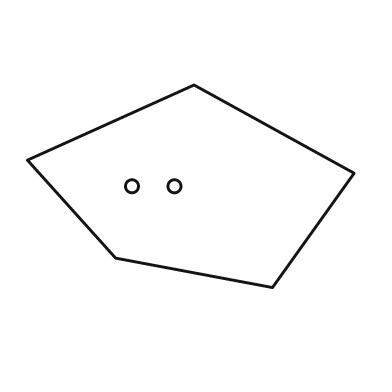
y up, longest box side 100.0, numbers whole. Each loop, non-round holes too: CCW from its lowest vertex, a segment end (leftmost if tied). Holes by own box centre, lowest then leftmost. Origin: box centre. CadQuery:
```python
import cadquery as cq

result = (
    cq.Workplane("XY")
    .moveTo(25.0, -31.0)
    .lineTo(50.0, 4.0)
    .lineTo(1.0, 31.0)
    .lineTo(-50.0, 8.0)
    .lineTo(-23.0, -22.0)
    .close()
    .moveTo(-18.0, 0.0)
    .circle(2.0)
    .moveTo(-5.0, 0.0)
    .circle(2.0)
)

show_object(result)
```